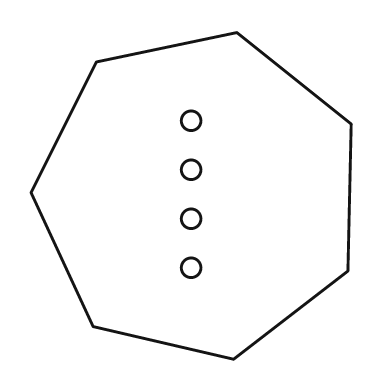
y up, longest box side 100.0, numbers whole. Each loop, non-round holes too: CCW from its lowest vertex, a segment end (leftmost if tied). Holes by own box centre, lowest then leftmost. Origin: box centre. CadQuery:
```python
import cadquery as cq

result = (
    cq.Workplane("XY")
    .moveTo(13.0, -50.0)
    .lineTo(48.0, -23.0)
    .lineTo(49.0, 22.0)
    .lineTo(14.0, 50.0)
    .lineTo(-29.0, 41.0)
    .lineTo(-49.0, 1.0)
    .lineTo(-30.0, -40.0)
    .close()
    .moveTo(0.0, -22.0)
    .circle(3.0)
    .moveTo(0.0, -7.0)
    .circle(3.0)
    .moveTo(0.0, 8.0)
    .circle(3.0)
    .moveTo(0.0, 23.0)
    .circle(3.0)
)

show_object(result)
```